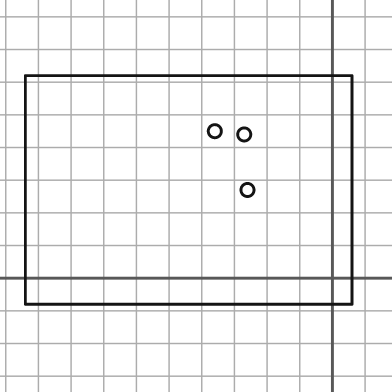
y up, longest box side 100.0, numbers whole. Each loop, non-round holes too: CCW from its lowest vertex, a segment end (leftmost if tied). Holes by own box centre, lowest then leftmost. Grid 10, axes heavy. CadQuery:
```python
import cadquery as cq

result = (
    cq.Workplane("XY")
    .moveTo(-94.0, -8.0)
    .lineTo(6.0, -8.0)
    .lineTo(6.0, 62.0)
    .lineTo(-94.0, 62.0)
    .close()
    .moveTo(-26.0, 27.0)
    .circle(2.0)
    .moveTo(-27.0, 44.0)
    .circle(2.0)
    .moveTo(-36.0, 45.0)
    .circle(2.0)
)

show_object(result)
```